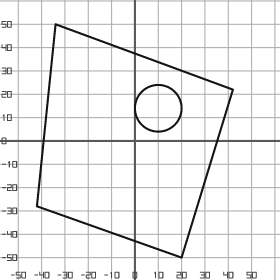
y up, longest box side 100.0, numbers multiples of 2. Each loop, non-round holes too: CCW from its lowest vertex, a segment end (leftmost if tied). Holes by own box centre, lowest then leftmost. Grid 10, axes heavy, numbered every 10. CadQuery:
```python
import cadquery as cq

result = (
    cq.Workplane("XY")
    .moveTo(20.0, -50.0)
    .lineTo(42.0, 22.0)
    .lineTo(-34.0, 50.0)
    .lineTo(-42.0, -28.0)
    .close()
    .moveTo(10.0, 14.0)
    .circle(10.0)
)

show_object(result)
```